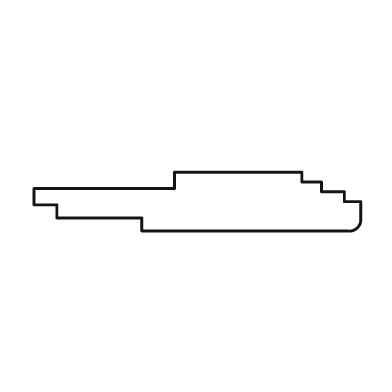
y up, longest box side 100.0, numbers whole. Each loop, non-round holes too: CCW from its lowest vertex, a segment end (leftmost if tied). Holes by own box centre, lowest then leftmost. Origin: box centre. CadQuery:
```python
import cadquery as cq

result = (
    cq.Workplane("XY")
    .moveTo(-17.0, -9.0)
    .lineTo(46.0, -9.0)
    .threePointArc((49.0, -8.0), (50.0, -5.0))
    .lineTo(50.0, 0.0)
    .lineTo(45.0, 0.0)
    .lineTo(45.0, 3.0)
    .lineTo(38.0, 3.0)
    .lineTo(38.0, 6.0)
    .lineTo(32.0, 6.0)
    .lineTo(32.0, 9.0)
    .lineTo(-7.0, 9.0)
    .lineTo(-7.0, 4.0)
    .lineTo(-50.0, 4.0)
    .lineTo(-50.0, -1.0)
    .lineTo(-43.0, -1.0)
    .lineTo(-43.0, -5.0)
    .lineTo(-17.0, -5.0)
    .close()
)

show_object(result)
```